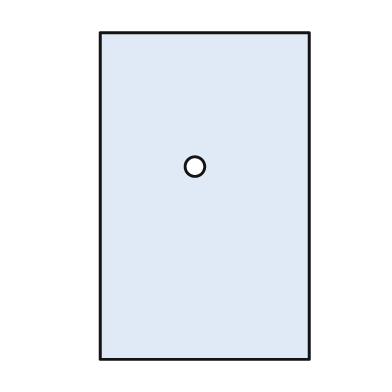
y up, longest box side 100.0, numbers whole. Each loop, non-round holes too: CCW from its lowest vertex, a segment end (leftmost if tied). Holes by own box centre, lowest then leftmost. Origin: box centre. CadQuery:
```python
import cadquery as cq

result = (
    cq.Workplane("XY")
    .moveTo(-32.0, -50.0)
    .lineTo(32.0, -50.0)
    .lineTo(32.0, 50.0)
    .lineTo(-32.0, 50.0)
    .close()
    .moveTo(-3.0, 9.0)
    .circle(3.0)
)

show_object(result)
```